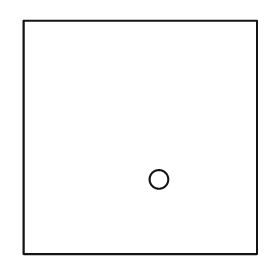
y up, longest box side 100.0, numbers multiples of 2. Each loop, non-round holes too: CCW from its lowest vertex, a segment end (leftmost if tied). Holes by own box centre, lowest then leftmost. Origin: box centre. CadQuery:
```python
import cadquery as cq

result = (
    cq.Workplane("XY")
    .moveTo(-50.0, -50.0)
    .lineTo(50.0, -50.0)
    .lineTo(50.0, 50.0)
    .lineTo(-50.0, 50.0)
    .close()
    .moveTo(8.0, -18.0)
    .circle(4.0)
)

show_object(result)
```